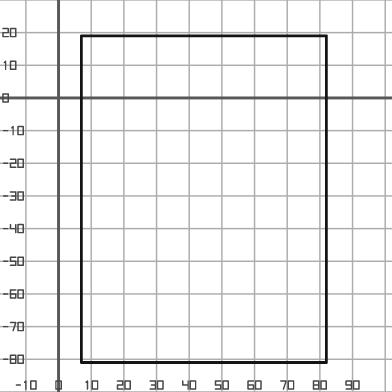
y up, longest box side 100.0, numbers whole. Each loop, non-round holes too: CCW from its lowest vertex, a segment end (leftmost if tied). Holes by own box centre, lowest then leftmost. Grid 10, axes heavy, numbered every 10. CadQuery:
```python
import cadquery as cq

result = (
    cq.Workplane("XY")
    .moveTo(7.0, -81.0)
    .lineTo(82.0, -81.0)
    .lineTo(82.0, 19.0)
    .lineTo(7.0, 19.0)
    .close()
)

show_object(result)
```